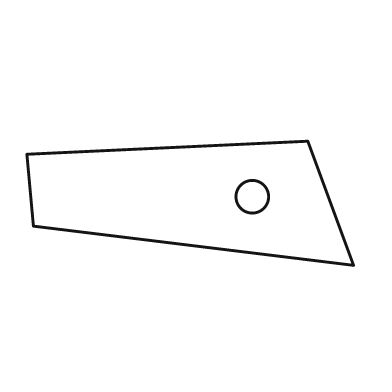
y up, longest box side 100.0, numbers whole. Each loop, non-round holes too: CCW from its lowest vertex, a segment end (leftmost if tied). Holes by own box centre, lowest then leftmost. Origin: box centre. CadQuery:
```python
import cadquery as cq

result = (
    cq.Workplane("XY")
    .moveTo(50.0, -19.0)
    .lineTo(36.0, 19.0)
    .lineTo(-50.0, 15.0)
    .lineTo(-48.0, -7.0)
    .close()
    .moveTo(19.0, 2.0)
    .circle(5.0)
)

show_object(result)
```